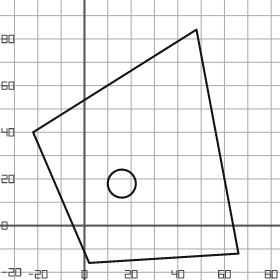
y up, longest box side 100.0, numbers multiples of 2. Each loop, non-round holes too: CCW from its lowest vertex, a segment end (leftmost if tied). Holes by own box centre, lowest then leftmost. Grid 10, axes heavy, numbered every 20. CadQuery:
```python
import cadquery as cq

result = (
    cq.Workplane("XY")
    .moveTo(2.0, -16.0)
    .lineTo(66.0, -12.0)
    .lineTo(48.0, 84.0)
    .lineTo(-22.0, 40.0)
    .close()
    .moveTo(16.0, 18.0)
    .circle(6.0)
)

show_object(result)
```